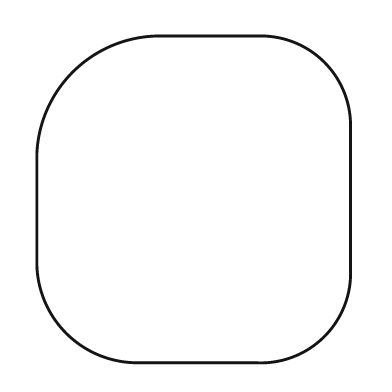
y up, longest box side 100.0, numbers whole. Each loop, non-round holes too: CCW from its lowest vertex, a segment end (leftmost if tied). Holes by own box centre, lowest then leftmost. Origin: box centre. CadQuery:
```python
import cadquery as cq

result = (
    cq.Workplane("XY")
    .moveTo(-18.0, -50.0)
    .lineTo(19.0, -50.0)
    .threePointArc((40.0, -42.0), (48.0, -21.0))
    .lineTo(48.0, 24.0)
    .threePointArc((40.0, 42.0), (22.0, 50.0))
    .lineTo(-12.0, 50.0)
    .threePointArc((-37.0, 39.0), (-48.0, 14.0))
    .lineTo(-48.0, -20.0)
    .threePointArc((-39.0, -41.0), (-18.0, -50.0))
    .close()
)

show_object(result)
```